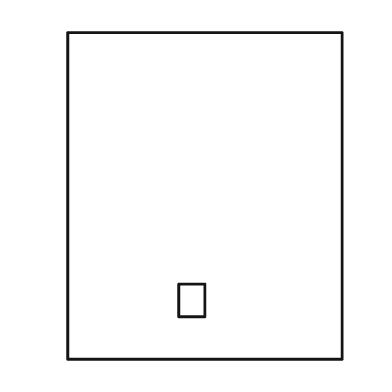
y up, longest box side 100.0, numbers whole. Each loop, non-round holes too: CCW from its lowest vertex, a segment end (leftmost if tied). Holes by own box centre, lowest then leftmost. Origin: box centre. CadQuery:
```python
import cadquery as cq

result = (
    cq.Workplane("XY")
    .moveTo(-42.0, -50.0)
    .lineTo(42.0, -50.0)
    .lineTo(42.0, 50.0)
    .lineTo(-42.0, 50.0)
    .close()
    .moveTo(-8.0, -37.0)
    .lineTo(0.0, -37.0)
    .lineTo(0.0, -27.0)
    .lineTo(-8.0, -27.0)
    .close()
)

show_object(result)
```